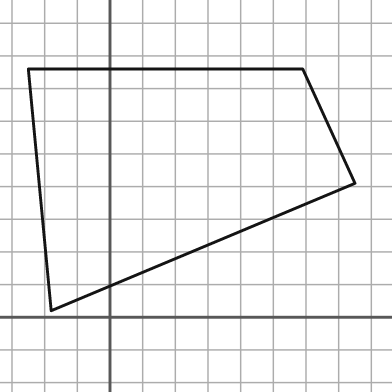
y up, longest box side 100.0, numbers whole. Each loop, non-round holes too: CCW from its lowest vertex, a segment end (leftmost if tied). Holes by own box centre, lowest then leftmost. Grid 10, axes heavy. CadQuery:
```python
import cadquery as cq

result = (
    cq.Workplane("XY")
    .moveTo(-18.0, 2.0)
    .lineTo(75.0, 41.0)
    .lineTo(59.0, 76.0)
    .lineTo(-25.0, 76.0)
    .close()
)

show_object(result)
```